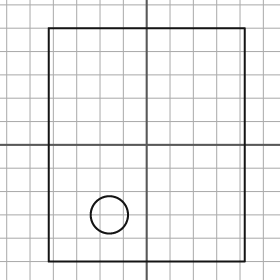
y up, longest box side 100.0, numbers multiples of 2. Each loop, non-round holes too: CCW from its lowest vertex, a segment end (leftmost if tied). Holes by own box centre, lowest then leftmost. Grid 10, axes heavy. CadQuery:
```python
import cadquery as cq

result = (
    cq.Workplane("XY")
    .moveTo(-42.0, -50.0)
    .lineTo(42.0, -50.0)
    .lineTo(42.0, 50.0)
    .lineTo(-42.0, 50.0)
    .close()
    .moveTo(-16.0, -30.0)
    .circle(8.0)
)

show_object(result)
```